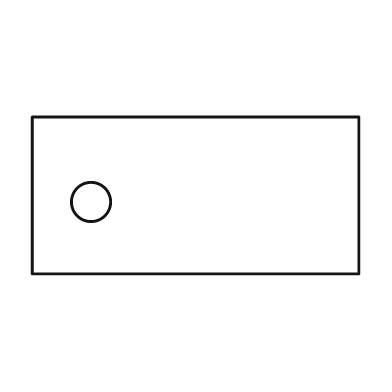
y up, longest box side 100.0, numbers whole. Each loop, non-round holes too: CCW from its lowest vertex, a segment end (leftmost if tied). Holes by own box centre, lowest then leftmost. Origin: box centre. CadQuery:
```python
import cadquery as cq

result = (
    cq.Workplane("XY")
    .moveTo(-50.0, -24.0)
    .lineTo(50.0, -24.0)
    .lineTo(50.0, 24.0)
    .lineTo(-50.0, 24.0)
    .close()
    .moveTo(-32.0, -2.0)
    .circle(6.0)
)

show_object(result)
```